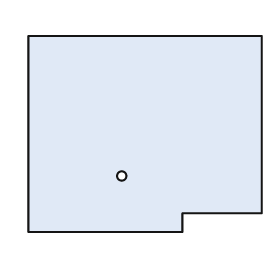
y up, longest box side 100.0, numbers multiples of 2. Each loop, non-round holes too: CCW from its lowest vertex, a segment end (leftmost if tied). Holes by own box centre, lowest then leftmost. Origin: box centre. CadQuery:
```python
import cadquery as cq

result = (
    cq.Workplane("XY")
    .moveTo(-50.0, -42.0)
    .lineTo(16.0, -42.0)
    .lineTo(16.0, -34.0)
    .lineTo(50.0, -34.0)
    .lineTo(50.0, 42.0)
    .lineTo(-50.0, 42.0)
    .close()
    .moveTo(-10.0, -18.0)
    .circle(2.0)
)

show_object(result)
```